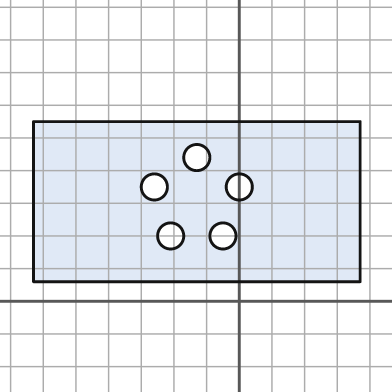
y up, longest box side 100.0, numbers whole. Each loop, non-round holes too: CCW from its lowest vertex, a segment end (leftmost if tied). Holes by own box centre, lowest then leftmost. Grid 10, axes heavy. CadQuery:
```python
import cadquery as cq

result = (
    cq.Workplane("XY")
    .moveTo(-63.0, 6.0)
    .lineTo(37.0, 6.0)
    .lineTo(37.0, 55.0)
    .lineTo(-63.0, 55.0)
    .close()
    .moveTo(-21.0, 20.0)
    .circle(4.0)
    .moveTo(-5.0, 20.0)
    .circle(4.0)
    .moveTo(-26.0, 35.0)
    .circle(4.0)
    .moveTo(0.0, 35.0)
    .circle(4.0)
    .moveTo(-13.0, 44.0)
    .circle(4.0)
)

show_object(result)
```